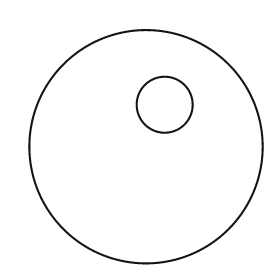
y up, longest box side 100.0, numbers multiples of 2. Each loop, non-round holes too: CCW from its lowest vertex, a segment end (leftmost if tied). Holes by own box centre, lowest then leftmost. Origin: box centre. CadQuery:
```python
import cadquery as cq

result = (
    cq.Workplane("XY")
    .moveTo(0.0, 0.0)
    .circle(50.0)
    .moveTo(8.0, 18.0)
    .circle(12.0)
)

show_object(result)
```